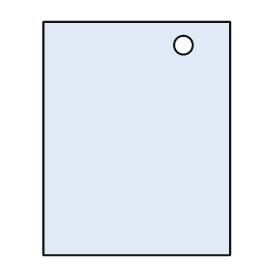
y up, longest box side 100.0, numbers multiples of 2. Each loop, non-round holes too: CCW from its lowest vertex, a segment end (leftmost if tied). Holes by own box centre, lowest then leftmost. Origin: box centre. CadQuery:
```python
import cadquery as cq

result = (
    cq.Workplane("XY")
    .moveTo(-40.0, -50.0)
    .lineTo(40.0, -50.0)
    .lineTo(40.0, 50.0)
    .lineTo(-40.0, 50.0)
    .close()
    .moveTo(20.0, 40.0)
    .circle(4.0)
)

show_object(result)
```